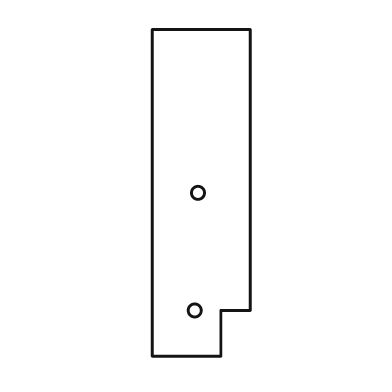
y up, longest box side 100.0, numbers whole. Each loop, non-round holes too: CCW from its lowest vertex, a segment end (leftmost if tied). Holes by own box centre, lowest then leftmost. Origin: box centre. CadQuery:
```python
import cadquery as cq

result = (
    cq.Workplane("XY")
    .moveTo(-15.0, -50.0)
    .lineTo(6.0, -50.0)
    .lineTo(6.0, -36.0)
    .lineTo(15.0, -36.0)
    .lineTo(15.0, 50.0)
    .lineTo(-15.0, 50.0)
    .close()
    .moveTo(-2.0, -36.0)
    .circle(2.0)
    .moveTo(-1.0, 0.0)
    .circle(2.0)
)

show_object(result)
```